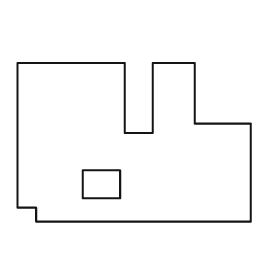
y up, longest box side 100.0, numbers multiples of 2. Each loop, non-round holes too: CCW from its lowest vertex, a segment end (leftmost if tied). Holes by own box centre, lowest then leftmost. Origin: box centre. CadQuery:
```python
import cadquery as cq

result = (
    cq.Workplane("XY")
    .moveTo(-42.0, -34.0)
    .lineTo(50.0, -34.0)
    .lineTo(50.0, 8.0)
    .lineTo(26.0, 8.0)
    .lineTo(26.0, 34.0)
    .lineTo(8.0, 34.0)
    .lineTo(8.0, 4.0)
    .lineTo(-4.0, 4.0)
    .lineTo(-4.0, 34.0)
    .lineTo(-50.0, 34.0)
    .lineTo(-50.0, -28.0)
    .lineTo(-42.0, -28.0)
    .close()
    .moveTo(-22.0, -24.0)
    .lineTo(-6.0, -24.0)
    .lineTo(-6.0, -12.0)
    .lineTo(-22.0, -12.0)
    .close()
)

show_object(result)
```